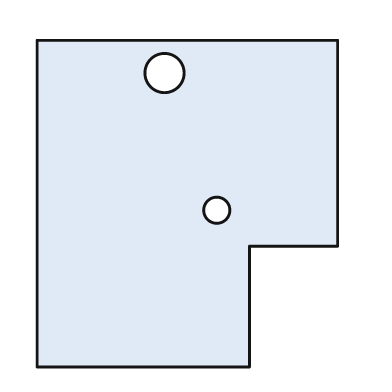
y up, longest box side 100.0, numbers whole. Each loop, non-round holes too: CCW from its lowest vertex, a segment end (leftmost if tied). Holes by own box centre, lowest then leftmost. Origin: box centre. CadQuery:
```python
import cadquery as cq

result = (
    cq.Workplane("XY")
    .moveTo(-46.0, -50.0)
    .lineTo(19.0, -50.0)
    .lineTo(19.0, -13.0)
    .lineTo(46.0, -13.0)
    .lineTo(46.0, 50.0)
    .lineTo(-46.0, 50.0)
    .close()
    .moveTo(9.0, -2.0)
    .circle(4.0)
    .moveTo(-7.0, 40.0)
    .circle(6.0)
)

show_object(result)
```